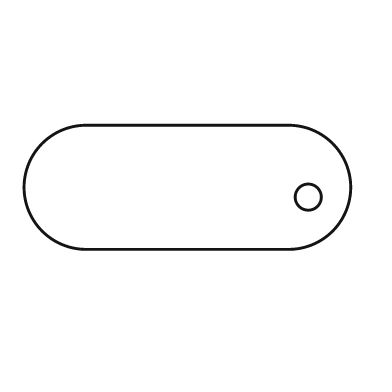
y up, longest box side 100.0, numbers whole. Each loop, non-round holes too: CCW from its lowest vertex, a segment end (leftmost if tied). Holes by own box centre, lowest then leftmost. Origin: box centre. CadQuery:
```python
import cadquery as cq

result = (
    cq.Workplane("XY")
    .moveTo(-31.0, -19.0)
    .lineTo(31.0, -19.0)
    .threePointArc((50.0, 0.0), (31.0, 19.0))
    .lineTo(-31.0, 19.0)
    .threePointArc((-50.0, 0.0), (-31.0, -19.0))
    .close()
    .moveTo(37.0, -3.0)
    .circle(4.0)
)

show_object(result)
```